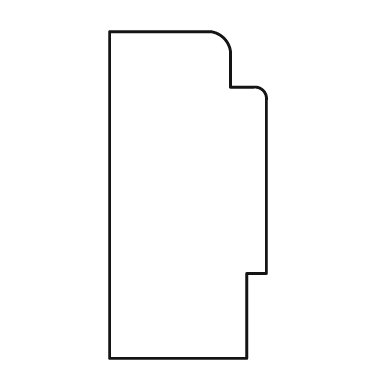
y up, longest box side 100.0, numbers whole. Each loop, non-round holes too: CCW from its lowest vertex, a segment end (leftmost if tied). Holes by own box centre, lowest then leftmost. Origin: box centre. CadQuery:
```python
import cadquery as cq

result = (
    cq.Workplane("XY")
    .moveTo(-24.0, -50.0)
    .lineTo(18.0, -50.0)
    .lineTo(18.0, -24.0)
    .lineTo(24.0, -24.0)
    .lineTo(24.0, 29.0)
    .threePointArc((23.0, 32.0), (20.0, 33.0))
    .lineTo(13.0, 33.0)
    .lineTo(13.0, 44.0)
    .threePointArc((11.0, 48.0), (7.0, 50.0))
    .lineTo(-24.0, 50.0)
    .close()
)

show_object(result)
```